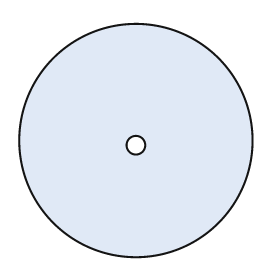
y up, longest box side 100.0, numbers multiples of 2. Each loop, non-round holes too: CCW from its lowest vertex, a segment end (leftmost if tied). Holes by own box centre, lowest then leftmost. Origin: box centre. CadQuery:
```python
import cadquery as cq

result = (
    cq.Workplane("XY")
    .moveTo(0.0, 0.0)
    .circle(50.0)
    .moveTo(0.0, -2.0)
    .circle(4.0)
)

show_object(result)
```